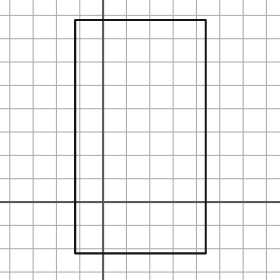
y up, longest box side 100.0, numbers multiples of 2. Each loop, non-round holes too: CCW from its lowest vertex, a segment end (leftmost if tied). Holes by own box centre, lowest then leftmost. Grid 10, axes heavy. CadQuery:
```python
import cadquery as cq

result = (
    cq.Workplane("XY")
    .moveTo(-12.0, -22.0)
    .lineTo(44.0, -22.0)
    .lineTo(44.0, 78.0)
    .lineTo(-12.0, 78.0)
    .close()
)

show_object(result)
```